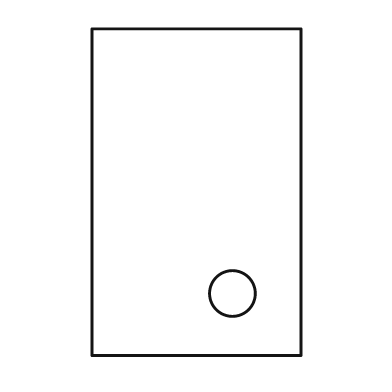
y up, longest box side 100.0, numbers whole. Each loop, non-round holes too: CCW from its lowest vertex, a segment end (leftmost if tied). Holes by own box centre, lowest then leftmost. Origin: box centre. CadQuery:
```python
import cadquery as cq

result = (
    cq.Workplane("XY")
    .moveTo(-32.0, -50.0)
    .lineTo(32.0, -50.0)
    .lineTo(32.0, 50.0)
    .lineTo(-32.0, 50.0)
    .close()
    .moveTo(11.0, -31.0)
    .circle(7.0)
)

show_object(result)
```